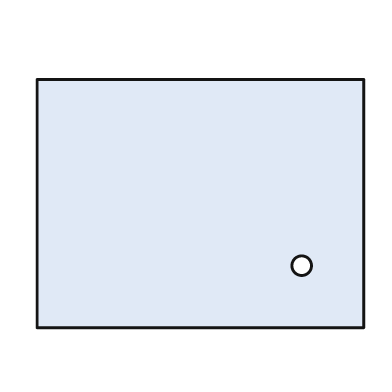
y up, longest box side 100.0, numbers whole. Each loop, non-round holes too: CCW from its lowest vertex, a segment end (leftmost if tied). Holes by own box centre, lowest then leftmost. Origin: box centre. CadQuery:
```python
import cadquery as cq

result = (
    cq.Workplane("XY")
    .moveTo(-50.0, -38.0)
    .lineTo(50.0, -38.0)
    .lineTo(50.0, 38.0)
    .lineTo(-50.0, 38.0)
    .close()
    .moveTo(31.0, -19.0)
    .circle(3.0)
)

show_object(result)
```